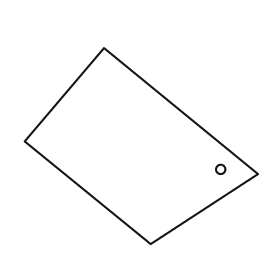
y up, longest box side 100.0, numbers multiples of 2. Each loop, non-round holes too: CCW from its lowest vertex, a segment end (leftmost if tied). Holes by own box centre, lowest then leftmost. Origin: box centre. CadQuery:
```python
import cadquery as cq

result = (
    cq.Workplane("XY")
    .moveTo(4.0, -42.0)
    .lineTo(50.0, -12.0)
    .lineTo(-16.0, 42.0)
    .lineTo(-50.0, 2.0)
    .close()
    .moveTo(34.0, -10.0)
    .circle(2.0)
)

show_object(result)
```